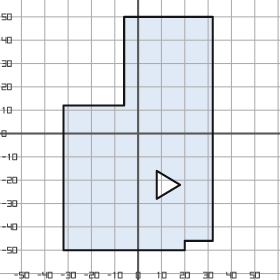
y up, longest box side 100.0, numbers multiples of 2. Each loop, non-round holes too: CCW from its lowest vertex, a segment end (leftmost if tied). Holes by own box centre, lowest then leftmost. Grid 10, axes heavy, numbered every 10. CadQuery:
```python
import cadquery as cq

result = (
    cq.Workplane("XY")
    .moveTo(-32.0, -50.0)
    .lineTo(20.0, -50.0)
    .lineTo(20.0, -46.0)
    .lineTo(32.0, -46.0)
    .lineTo(32.0, 50.0)
    .lineTo(-6.0, 50.0)
    .lineTo(-6.0, 12.0)
    .lineTo(-32.0, 12.0)
    .close()
    .moveTo(8.0, -28.0)
    .lineTo(18.0, -22.0)
    .lineTo(8.0, -16.0)
    .close()
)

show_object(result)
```